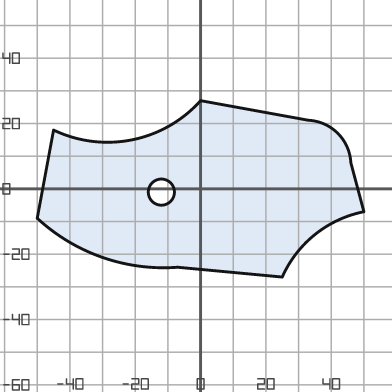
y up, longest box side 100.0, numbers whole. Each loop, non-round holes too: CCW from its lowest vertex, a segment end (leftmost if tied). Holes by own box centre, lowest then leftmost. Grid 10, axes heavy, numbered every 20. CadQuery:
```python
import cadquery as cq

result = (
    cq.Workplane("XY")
    .moveTo(25.0, -27.0)
    .threePointArc((35.0, -14.0), (50.0, -7.0))
    .lineTo(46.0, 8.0)
    .threePointArc((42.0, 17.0), (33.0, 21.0))
    .lineTo(0.0, 27.0)
    .threePointArc((-21.0, 15.0), (-45.0, 18.0))
    .lineTo(-50.0, -9.0)
    .threePointArc((-30.0, -21.0), (-7.0, -24.0))
    .close()
    .moveTo(-12.0, -1.0)
    .circle(4.0)
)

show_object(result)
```